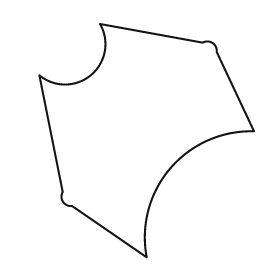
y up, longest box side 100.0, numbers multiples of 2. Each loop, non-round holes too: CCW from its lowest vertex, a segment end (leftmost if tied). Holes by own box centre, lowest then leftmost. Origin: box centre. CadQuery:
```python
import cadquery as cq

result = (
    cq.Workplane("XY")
    .moveTo(0.0, -50.0)
    .threePointArc((10.0, -12.0), (46.0, 4.0))
    .lineTo(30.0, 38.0)
    .threePointArc((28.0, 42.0), (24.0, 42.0))
    .lineTo(-20.0, 50.0)
    .threePointArc((-24.0, 28.0), (-46.0, 28.0))
    .lineTo(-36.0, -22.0)
    .threePointArc((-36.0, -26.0), (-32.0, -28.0))
    .close()
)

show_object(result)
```